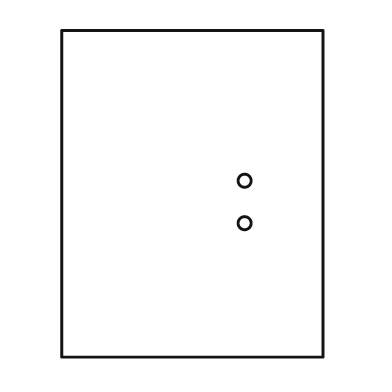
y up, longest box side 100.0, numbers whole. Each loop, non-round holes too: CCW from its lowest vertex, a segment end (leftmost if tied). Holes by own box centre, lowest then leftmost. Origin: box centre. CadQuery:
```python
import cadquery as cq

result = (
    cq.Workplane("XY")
    .moveTo(-40.0, -50.0)
    .lineTo(40.0, -50.0)
    .lineTo(40.0, 50.0)
    .lineTo(-40.0, 50.0)
    .close()
    .moveTo(16.0, -9.0)
    .circle(2.0)
    .moveTo(16.0, 4.0)
    .circle(2.0)
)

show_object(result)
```